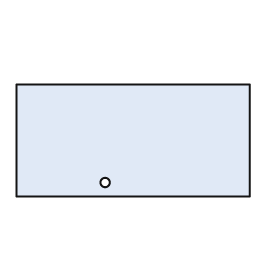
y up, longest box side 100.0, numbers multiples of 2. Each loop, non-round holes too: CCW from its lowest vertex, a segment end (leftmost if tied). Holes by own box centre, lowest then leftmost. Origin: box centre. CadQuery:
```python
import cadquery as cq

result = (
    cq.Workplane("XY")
    .moveTo(-50.0, -24.0)
    .lineTo(50.0, -24.0)
    .lineTo(50.0, 24.0)
    .lineTo(-50.0, 24.0)
    .close()
    .moveTo(-12.0, -18.0)
    .circle(2.0)
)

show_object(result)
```